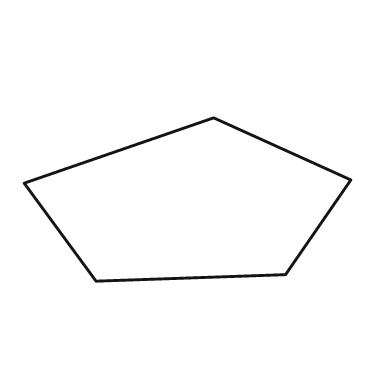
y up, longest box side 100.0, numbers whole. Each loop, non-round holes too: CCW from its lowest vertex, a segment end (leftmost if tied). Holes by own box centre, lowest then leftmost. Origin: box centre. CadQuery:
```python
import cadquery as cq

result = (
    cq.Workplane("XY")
    .moveTo(-28.0, -25.0)
    .lineTo(30.0, -23.0)
    .lineTo(50.0, 6.0)
    .lineTo(8.0, 25.0)
    .lineTo(-50.0, 5.0)
    .close()
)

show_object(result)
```